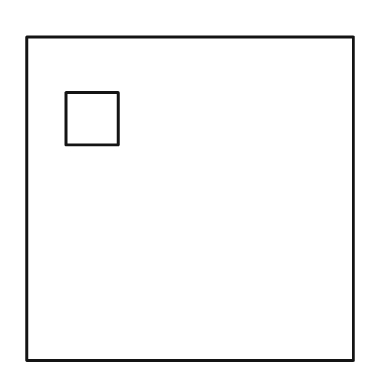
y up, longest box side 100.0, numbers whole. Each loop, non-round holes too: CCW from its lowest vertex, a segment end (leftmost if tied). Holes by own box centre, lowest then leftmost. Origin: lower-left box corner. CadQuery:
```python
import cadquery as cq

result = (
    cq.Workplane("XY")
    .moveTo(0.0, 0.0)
    .lineTo(100.0, 0.0)
    .lineTo(100.0, 99.0)
    .lineTo(0.0, 99.0)
    .close()
    .moveTo(12.0, 66.0)
    .lineTo(28.0, 66.0)
    .lineTo(28.0, 82.0)
    .lineTo(12.0, 82.0)
    .close()
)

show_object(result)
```